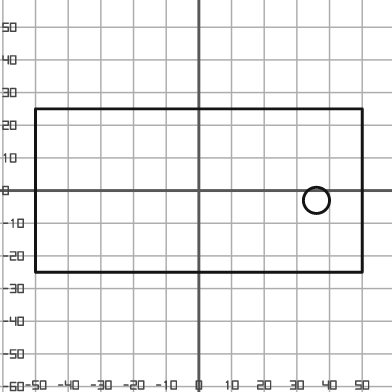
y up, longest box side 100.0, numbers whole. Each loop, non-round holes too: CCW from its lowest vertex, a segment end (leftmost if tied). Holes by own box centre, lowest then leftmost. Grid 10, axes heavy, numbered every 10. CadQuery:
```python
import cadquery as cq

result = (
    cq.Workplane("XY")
    .moveTo(-50.0, -25.0)
    .lineTo(50.0, -25.0)
    .lineTo(50.0, 25.0)
    .lineTo(-50.0, 25.0)
    .close()
    .moveTo(36.0, -3.0)
    .circle(4.0)
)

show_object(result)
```